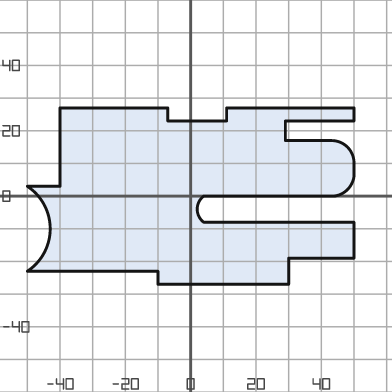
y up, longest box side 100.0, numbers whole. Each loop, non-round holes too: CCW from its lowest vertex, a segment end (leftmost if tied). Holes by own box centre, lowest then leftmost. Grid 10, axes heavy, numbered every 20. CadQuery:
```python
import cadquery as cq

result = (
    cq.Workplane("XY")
    .moveTo(-10.0, -27.0)
    .lineTo(30.0, -27.0)
    .lineTo(30.0, -19.0)
    .lineTo(50.0, -19.0)
    .lineTo(50.0, -8.0)
    .lineTo(4.0, -8.0)
    .threePointArc((2.0, -4.0), (4.0, 0.0))
    .lineTo(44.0, 0.0)
    .threePointArc((48.0, 2.0), (50.0, 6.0))
    .lineTo(50.0, 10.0)
    .threePointArc((48.0, 15.0), (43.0, 17.0))
    .lineTo(29.0, 17.0)
    .lineTo(29.0, 23.0)
    .lineTo(50.0, 23.0)
    .lineTo(50.0, 27.0)
    .lineTo(11.0, 27.0)
    .lineTo(11.0, 23.0)
    .lineTo(-7.0, 23.0)
    .lineTo(-7.0, 27.0)
    .lineTo(-40.0, 27.0)
    .lineTo(-40.0, 3.0)
    .lineTo(-50.0, 3.0)
    .threePointArc((-43.0, -10.0), (-50.0, -23.0))
    .lineTo(-10.0, -23.0)
    .close()
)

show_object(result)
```